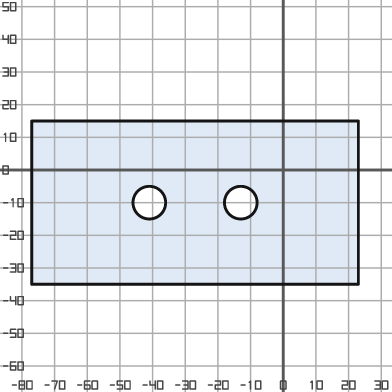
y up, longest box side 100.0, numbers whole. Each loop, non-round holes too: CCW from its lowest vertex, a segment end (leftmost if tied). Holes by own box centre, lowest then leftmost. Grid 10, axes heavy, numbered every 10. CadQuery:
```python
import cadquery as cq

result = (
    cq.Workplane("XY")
    .moveTo(-77.0, -35.0)
    .lineTo(23.0, -35.0)
    .lineTo(23.0, 15.0)
    .lineTo(-77.0, 15.0)
    .close()
    .moveTo(-41.0, -10.0)
    .circle(5.0)
    .moveTo(-13.0, -10.0)
    .circle(5.0)
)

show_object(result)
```